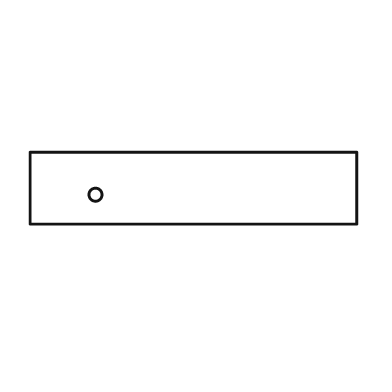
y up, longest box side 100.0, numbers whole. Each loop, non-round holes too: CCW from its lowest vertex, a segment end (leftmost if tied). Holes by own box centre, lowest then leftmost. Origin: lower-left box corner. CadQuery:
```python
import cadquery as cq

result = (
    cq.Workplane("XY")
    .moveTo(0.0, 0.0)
    .lineTo(100.0, 0.0)
    .lineTo(100.0, 22.0)
    .lineTo(0.0, 22.0)
    .close()
    .moveTo(20.0, 9.0)
    .circle(2.0)
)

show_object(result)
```